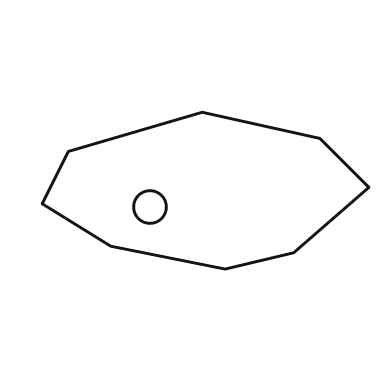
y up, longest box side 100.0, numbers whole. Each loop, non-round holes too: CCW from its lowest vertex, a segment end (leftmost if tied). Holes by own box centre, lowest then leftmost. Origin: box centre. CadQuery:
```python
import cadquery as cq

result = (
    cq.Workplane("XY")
    .moveTo(6.0, -24.0)
    .lineTo(27.0, -19.0)
    .lineTo(50.0, 1.0)
    .lineTo(35.0, 16.0)
    .lineTo(-1.0, 24.0)
    .lineTo(-42.0, 12.0)
    .lineTo(-50.0, -4.0)
    .lineTo(-29.0, -17.0)
    .close()
    .moveTo(-17.0, -5.0)
    .circle(5.0)
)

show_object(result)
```